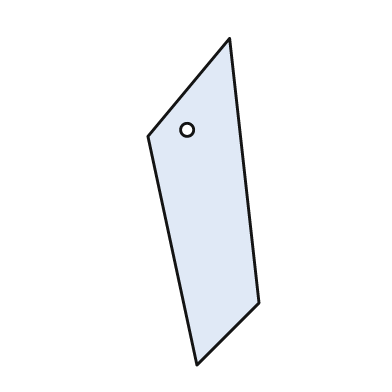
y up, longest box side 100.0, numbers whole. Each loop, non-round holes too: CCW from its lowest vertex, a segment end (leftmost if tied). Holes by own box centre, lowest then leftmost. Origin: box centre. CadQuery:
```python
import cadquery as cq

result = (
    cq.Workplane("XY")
    .moveTo(-2.0, -50.0)
    .lineTo(17.0, -31.0)
    .lineTo(8.0, 50.0)
    .lineTo(-17.0, 20.0)
    .close()
    .moveTo(-5.0, 22.0)
    .circle(2.0)
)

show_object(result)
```